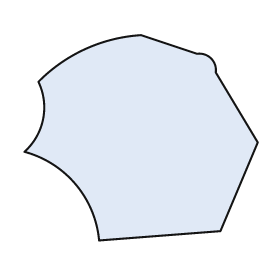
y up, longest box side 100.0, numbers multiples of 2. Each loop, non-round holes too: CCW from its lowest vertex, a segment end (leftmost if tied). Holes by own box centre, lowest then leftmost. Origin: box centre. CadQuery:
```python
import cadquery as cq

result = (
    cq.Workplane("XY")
    .moveTo(-18.0, -44.0)
    .lineTo(34.0, -40.0)
    .lineTo(50.0, -2.0)
    .lineTo(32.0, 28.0)
    .threePointArc((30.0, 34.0), (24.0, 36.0))
    .lineTo(0.0, 44.0)
    .threePointArc((-24.0, 38.0), (-44.0, 24.0))
    .threePointArc((-42.0, 8.0), (-50.0, -6.0))
    .threePointArc((-28.0, -20.0), (-18.0, -44.0))
    .close()
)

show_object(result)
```